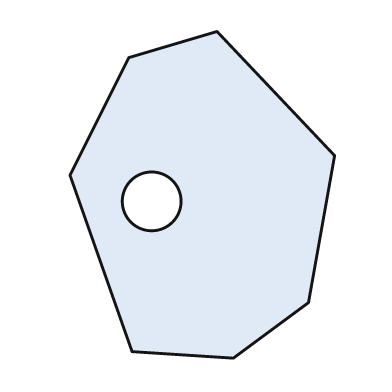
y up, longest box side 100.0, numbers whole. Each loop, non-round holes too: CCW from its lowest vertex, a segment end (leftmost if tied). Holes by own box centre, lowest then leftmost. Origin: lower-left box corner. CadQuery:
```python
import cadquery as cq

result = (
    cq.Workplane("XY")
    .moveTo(50.0, 0.0)
    .lineTo(73.0, 17.0)
    .lineTo(81.0, 62.0)
    .lineTo(45.0, 100.0)
    .lineTo(18.0, 92.0)
    .lineTo(0.0, 56.0)
    .lineTo(19.0, 2.0)
    .close()
    .moveTo(25.0, 48.0)
    .circle(9.0)
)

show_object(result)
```